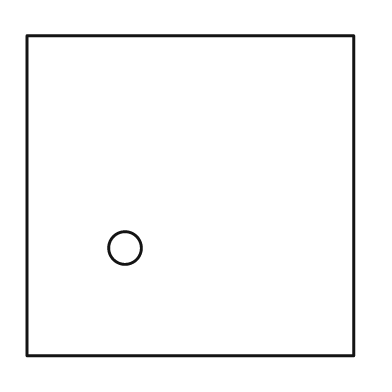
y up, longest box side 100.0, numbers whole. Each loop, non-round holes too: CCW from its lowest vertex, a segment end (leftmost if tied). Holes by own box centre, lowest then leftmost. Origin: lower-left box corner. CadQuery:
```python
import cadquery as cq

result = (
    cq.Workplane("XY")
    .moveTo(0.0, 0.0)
    .lineTo(100.0, 0.0)
    .lineTo(100.0, 98.0)
    .lineTo(0.0, 98.0)
    .close()
    .moveTo(30.0, 33.0)
    .circle(5.0)
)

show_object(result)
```